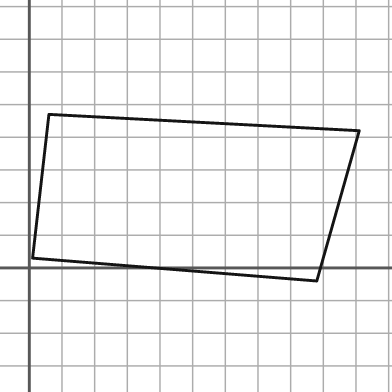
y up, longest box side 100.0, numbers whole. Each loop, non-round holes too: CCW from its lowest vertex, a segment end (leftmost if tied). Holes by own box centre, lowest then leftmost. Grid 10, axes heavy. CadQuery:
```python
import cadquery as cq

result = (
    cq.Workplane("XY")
    .moveTo(88.0, -4.0)
    .lineTo(101.0, 42.0)
    .lineTo(6.0, 47.0)
    .lineTo(1.0, 3.0)
    .close()
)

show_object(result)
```